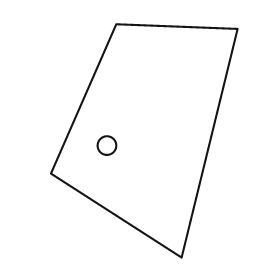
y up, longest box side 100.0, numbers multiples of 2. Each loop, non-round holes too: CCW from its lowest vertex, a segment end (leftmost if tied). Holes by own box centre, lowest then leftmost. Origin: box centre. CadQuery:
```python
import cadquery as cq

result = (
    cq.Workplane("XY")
    .moveTo(16.0, -50.0)
    .lineTo(40.0, 48.0)
    .lineTo(-12.0, 50.0)
    .lineTo(-40.0, -14.0)
    .close()
    .moveTo(-16.0, -2.0)
    .circle(4.0)
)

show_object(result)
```